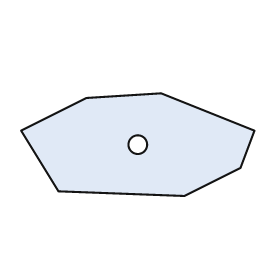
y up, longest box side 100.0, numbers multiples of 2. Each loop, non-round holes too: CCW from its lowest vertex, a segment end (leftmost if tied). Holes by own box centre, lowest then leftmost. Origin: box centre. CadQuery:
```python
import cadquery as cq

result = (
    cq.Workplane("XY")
    .moveTo(20.0, -22.0)
    .lineTo(44.0, -10.0)
    .lineTo(50.0, 6.0)
    .lineTo(10.0, 22.0)
    .lineTo(-22.0, 20.0)
    .lineTo(-50.0, 6.0)
    .lineTo(-34.0, -20.0)
    .close()
    .moveTo(0.0, 0.0)
    .circle(4.0)
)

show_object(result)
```